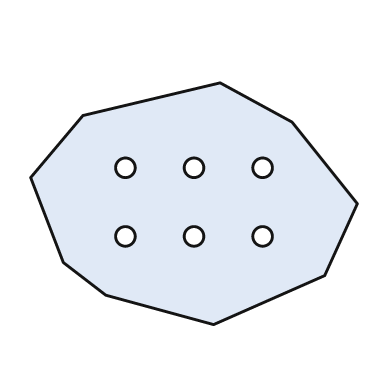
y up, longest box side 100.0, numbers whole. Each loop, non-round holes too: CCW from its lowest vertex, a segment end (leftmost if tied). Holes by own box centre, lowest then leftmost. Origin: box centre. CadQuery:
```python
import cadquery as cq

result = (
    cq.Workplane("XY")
    .moveTo(6.0, -37.0)
    .lineTo(40.0, -22.0)
    .lineTo(50.0, 0.0)
    .lineTo(30.0, 25.0)
    .lineTo(8.0, 37.0)
    .lineTo(-34.0, 27.0)
    .lineTo(-50.0, 8.0)
    .lineTo(-40.0, -18.0)
    .lineTo(-27.0, -28.0)
    .close()
    .moveTo(-21.0, -10.0)
    .circle(3.0)
    .moveTo(0.0, -10.0)
    .circle(3.0)
    .moveTo(21.0, -10.0)
    .circle(3.0)
    .moveTo(-21.0, 11.0)
    .circle(3.0)
    .moveTo(0.0, 11.0)
    .circle(3.0)
    .moveTo(21.0, 11.0)
    .circle(3.0)
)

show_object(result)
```